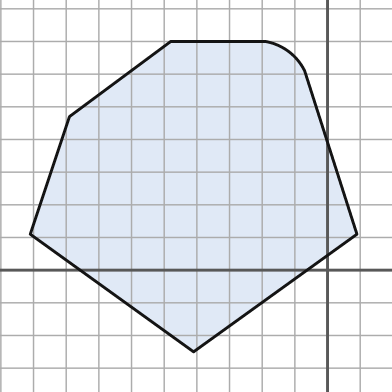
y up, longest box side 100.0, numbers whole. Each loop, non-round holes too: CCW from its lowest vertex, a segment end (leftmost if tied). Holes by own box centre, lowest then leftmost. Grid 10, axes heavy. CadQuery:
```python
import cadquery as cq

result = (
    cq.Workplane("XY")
    .moveTo(-41.0, -25.0)
    .lineTo(9.0, 11.0)
    .lineTo(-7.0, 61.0)
    .threePointArc((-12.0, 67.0), (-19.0, 70.0))
    .lineTo(-48.0, 70.0)
    .lineTo(-79.0, 47.0)
    .lineTo(-91.0, 11.0)
    .close()
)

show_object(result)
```